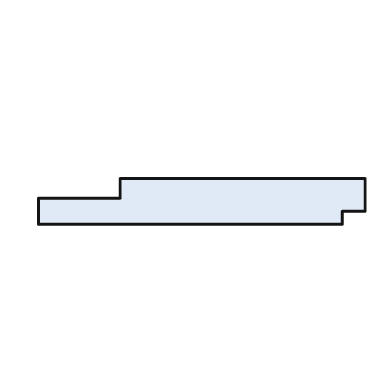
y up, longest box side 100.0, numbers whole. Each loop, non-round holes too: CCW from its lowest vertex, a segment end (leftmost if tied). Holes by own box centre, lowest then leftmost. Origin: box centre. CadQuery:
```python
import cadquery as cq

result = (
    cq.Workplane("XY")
    .moveTo(-50.0, -7.0)
    .lineTo(43.0, -7.0)
    .lineTo(43.0, -3.0)
    .lineTo(50.0, -3.0)
    .lineTo(50.0, 7.0)
    .lineTo(-25.0, 7.0)
    .lineTo(-25.0, 1.0)
    .lineTo(-50.0, 1.0)
    .close()
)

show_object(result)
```